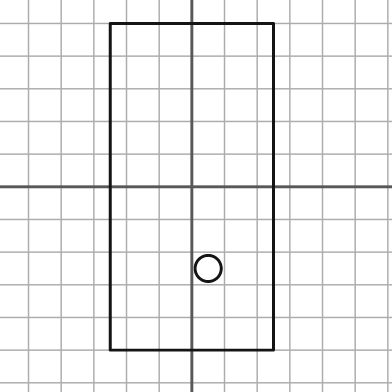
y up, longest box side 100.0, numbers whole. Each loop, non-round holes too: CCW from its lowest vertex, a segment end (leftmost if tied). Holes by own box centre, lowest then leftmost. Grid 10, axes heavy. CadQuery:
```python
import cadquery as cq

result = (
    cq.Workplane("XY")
    .moveTo(-25.0, -50.0)
    .lineTo(25.0, -50.0)
    .lineTo(25.0, 50.0)
    .lineTo(-25.0, 50.0)
    .close()
    .moveTo(5.0, -25.0)
    .circle(4.0)
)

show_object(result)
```